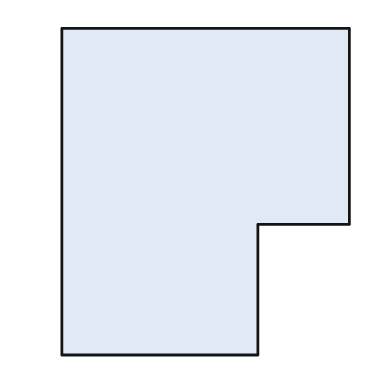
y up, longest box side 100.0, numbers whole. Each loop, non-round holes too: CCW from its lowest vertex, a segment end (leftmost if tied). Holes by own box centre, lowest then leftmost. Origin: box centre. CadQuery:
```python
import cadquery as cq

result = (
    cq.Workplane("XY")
    .moveTo(-44.0, -50.0)
    .lineTo(16.0, -50.0)
    .lineTo(16.0, -10.0)
    .lineTo(44.0, -10.0)
    .lineTo(44.0, 50.0)
    .lineTo(-44.0, 50.0)
    .close()
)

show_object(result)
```